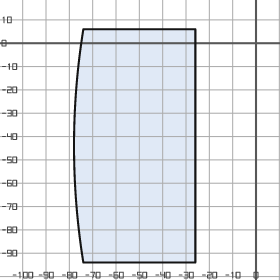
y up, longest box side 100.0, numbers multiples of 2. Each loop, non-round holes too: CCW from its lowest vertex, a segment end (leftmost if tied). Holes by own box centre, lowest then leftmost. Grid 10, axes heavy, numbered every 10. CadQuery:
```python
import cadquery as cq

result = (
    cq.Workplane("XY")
    .moveTo(-74.0, -94.0)
    .lineTo(-26.0, -94.0)
    .lineTo(-26.0, 6.0)
    .lineTo(-74.0, 6.0)
    .threePointArc((-78.0, -44.0), (-74.0, -94.0))
    .close()
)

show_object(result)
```